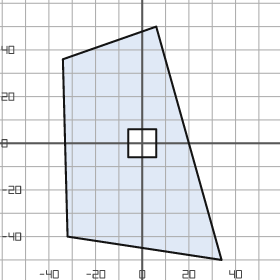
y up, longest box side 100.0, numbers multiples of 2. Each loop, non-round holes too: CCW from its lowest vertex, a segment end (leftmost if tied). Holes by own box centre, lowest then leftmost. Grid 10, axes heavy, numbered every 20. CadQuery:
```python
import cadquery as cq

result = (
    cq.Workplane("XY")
    .moveTo(34.0, -50.0)
    .lineTo(6.0, 50.0)
    .lineTo(-34.0, 36.0)
    .lineTo(-32.0, -40.0)
    .close()
    .moveTo(-6.0, -6.0)
    .lineTo(6.0, -6.0)
    .lineTo(6.0, 6.0)
    .lineTo(-6.0, 6.0)
    .close()
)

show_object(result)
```